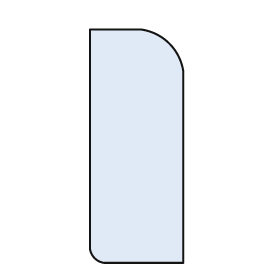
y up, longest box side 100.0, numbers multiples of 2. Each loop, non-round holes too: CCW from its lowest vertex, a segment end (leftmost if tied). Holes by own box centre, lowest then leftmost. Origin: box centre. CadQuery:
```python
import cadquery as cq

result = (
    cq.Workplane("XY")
    .moveTo(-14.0, -50.0)
    .lineTo(20.0, -50.0)
    .lineTo(20.0, 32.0)
    .threePointArc((14.0, 44.0), (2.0, 50.0))
    .lineTo(-20.0, 50.0)
    .lineTo(-20.0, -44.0)
    .threePointArc((-18.0, -48.0), (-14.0, -50.0))
    .close()
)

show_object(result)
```